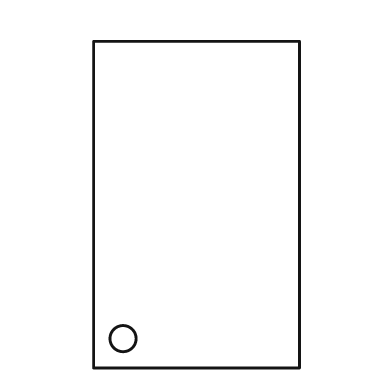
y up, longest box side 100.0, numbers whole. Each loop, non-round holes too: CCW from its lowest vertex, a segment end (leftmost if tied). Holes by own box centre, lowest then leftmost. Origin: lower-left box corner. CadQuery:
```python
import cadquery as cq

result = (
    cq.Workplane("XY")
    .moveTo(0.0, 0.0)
    .lineTo(63.0, 0.0)
    .lineTo(63.0, 100.0)
    .lineTo(0.0, 100.0)
    .close()
    .moveTo(9.0, 9.0)
    .circle(4.0)
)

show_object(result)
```